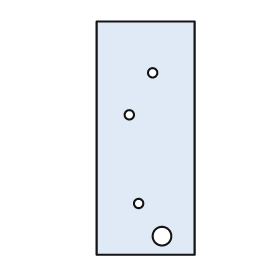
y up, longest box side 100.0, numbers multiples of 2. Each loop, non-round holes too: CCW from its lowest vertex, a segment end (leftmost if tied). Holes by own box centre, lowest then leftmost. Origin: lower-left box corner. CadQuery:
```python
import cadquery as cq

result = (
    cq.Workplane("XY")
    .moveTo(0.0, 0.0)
    .lineTo(42.0, 0.0)
    .lineTo(42.0, 100.0)
    .lineTo(0.0, 100.0)
    .close()
    .moveTo(28.0, 8.0)
    .circle(4.0)
    .moveTo(18.0, 22.0)
    .circle(2.0)
    .moveTo(14.0, 60.0)
    .circle(2.0)
    .moveTo(24.0, 78.0)
    .circle(2.0)
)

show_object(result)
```